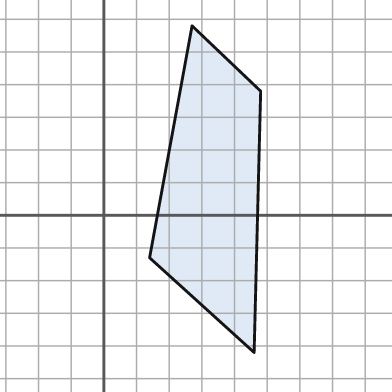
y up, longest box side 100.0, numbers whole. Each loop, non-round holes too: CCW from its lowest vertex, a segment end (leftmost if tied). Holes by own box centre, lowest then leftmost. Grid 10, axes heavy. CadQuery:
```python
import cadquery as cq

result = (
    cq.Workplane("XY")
    .moveTo(46.0, -42.0)
    .lineTo(48.0, 38.0)
    .lineTo(27.0, 58.0)
    .lineTo(14.0, -13.0)
    .close()
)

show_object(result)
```